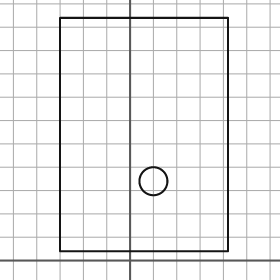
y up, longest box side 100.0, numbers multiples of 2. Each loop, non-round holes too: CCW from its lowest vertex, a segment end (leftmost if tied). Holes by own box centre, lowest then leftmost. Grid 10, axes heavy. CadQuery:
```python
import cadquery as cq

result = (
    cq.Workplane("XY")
    .moveTo(-30.0, 4.0)
    .lineTo(42.0, 4.0)
    .lineTo(42.0, 104.0)
    .lineTo(-30.0, 104.0)
    .close()
    .moveTo(10.0, 34.0)
    .circle(6.0)
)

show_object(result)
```